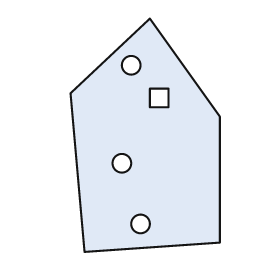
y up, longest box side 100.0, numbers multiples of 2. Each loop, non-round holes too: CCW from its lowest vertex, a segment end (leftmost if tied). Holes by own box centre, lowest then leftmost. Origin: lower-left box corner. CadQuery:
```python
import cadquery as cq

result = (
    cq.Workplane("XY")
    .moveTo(6.0, 0.0)
    .lineTo(64.0, 4.0)
    .lineTo(64.0, 58.0)
    .lineTo(34.0, 100.0)
    .lineTo(0.0, 68.0)
    .close()
    .moveTo(30.0, 12.0)
    .circle(4.0)
    .moveTo(22.0, 38.0)
    .circle(4.0)
    .moveTo(34.0, 62.0)
    .lineTo(42.0, 62.0)
    .lineTo(42.0, 70.0)
    .lineTo(34.0, 70.0)
    .close()
    .moveTo(26.0, 80.0)
    .circle(4.0)
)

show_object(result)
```